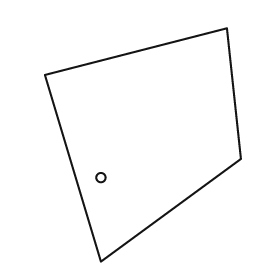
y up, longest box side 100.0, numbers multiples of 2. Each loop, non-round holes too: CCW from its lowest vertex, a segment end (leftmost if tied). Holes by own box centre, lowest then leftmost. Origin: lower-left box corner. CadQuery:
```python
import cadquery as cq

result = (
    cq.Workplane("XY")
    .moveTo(24.0, 0.0)
    .lineTo(84.0, 44.0)
    .lineTo(78.0, 100.0)
    .lineTo(0.0, 80.0)
    .close()
    .moveTo(24.0, 36.0)
    .circle(2.0)
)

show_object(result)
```